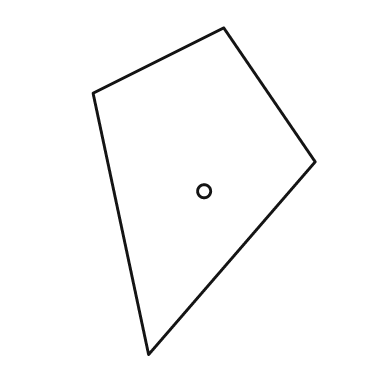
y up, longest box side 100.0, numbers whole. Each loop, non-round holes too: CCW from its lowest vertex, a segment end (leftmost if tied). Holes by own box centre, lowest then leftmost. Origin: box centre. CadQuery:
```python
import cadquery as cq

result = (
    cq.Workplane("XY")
    .moveTo(-17.0, -50.0)
    .lineTo(34.0, 9.0)
    .lineTo(6.0, 50.0)
    .lineTo(-34.0, 30.0)
    .close()
    .moveTo(0.0, 0.0)
    .circle(2.0)
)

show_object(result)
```